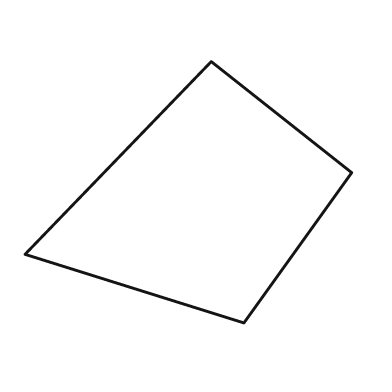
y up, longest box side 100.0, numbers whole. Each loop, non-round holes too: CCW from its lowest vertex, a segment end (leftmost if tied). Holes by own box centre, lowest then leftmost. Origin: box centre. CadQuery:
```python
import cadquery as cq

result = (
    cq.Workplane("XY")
    .moveTo(17.0, -40.0)
    .lineTo(50.0, 6.0)
    .lineTo(7.0, 40.0)
    .lineTo(-50.0, -19.0)
    .close()
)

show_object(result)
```